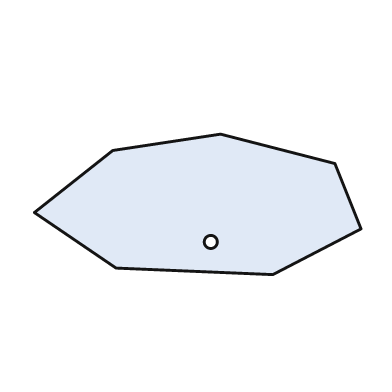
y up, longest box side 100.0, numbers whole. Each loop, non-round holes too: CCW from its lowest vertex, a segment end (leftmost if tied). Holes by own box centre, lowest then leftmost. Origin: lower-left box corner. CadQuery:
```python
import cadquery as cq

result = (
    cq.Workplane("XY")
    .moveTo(73.0, 0.0)
    .lineTo(100.0, 14.0)
    .lineTo(92.0, 34.0)
    .lineTo(57.0, 43.0)
    .lineTo(24.0, 38.0)
    .lineTo(0.0, 19.0)
    .lineTo(25.0, 2.0)
    .close()
    .moveTo(54.0, 10.0)
    .circle(2.0)
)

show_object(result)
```